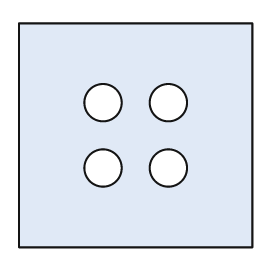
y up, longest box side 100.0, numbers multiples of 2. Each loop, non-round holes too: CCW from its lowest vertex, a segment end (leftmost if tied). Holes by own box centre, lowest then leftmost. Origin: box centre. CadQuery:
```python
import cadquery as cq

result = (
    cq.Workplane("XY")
    .moveTo(-50.0, -48.0)
    .lineTo(50.0, -48.0)
    .lineTo(50.0, 48.0)
    .lineTo(-50.0, 48.0)
    .close()
    .moveTo(-14.0, -14.0)
    .circle(8.0)
    .moveTo(14.0, -14.0)
    .circle(8.0)
    .moveTo(-14.0, 14.0)
    .circle(8.0)
    .moveTo(14.0, 14.0)
    .circle(8.0)
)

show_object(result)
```